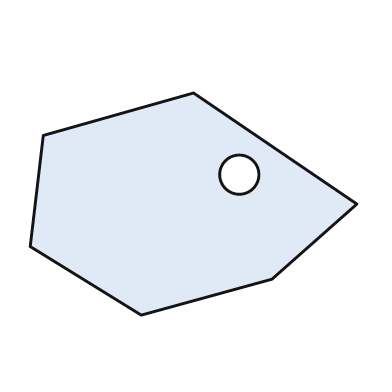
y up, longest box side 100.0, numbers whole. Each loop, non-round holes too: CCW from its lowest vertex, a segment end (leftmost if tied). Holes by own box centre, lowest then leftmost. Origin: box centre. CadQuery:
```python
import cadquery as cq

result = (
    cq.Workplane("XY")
    .moveTo(-16.0, -34.0)
    .lineTo(24.0, -23.0)
    .lineTo(50.0, 0.0)
    .lineTo(0.0, 34.0)
    .lineTo(-46.0, 21.0)
    .lineTo(-50.0, -13.0)
    .close()
    .moveTo(14.0, 9.0)
    .circle(6.0)
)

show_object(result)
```